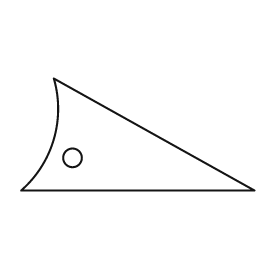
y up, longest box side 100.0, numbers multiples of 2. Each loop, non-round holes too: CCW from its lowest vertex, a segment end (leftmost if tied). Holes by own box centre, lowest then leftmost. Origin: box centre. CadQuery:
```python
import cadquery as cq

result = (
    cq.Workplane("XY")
    .moveTo(-50.0, -24.0)
    .lineTo(50.0, -24.0)
    .lineTo(-36.0, 24.0)
    .threePointArc((-36.0, -2.0), (-50.0, -24.0))
    .close()
    .moveTo(-28.0, -10.0)
    .circle(4.0)
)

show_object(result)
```